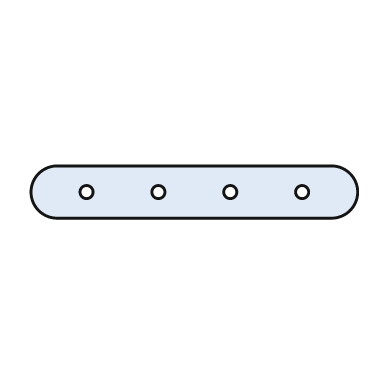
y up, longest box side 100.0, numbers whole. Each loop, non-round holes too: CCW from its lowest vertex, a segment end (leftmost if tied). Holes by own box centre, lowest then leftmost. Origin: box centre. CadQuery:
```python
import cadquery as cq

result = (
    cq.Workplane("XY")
    .moveTo(-42.0, -8.0)
    .lineTo(42.0, -8.0)
    .threePointArc((50.0, 0.0), (42.0, 8.0))
    .lineTo(-42.0, 8.0)
    .threePointArc((-50.0, 0.0), (-42.0, -8.0))
    .close()
    .moveTo(-33.0, 0.0)
    .circle(2.0)
    .moveTo(-11.0, 0.0)
    .circle(2.0)
    .moveTo(11.0, 0.0)
    .circle(2.0)
    .moveTo(33.0, 0.0)
    .circle(2.0)
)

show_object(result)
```